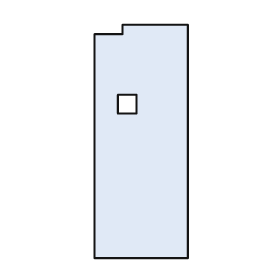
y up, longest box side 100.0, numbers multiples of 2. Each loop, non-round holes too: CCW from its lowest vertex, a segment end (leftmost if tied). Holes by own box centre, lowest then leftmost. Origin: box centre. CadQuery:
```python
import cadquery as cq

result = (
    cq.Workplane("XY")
    .moveTo(-20.0, -50.0)
    .lineTo(20.0, -50.0)
    .lineTo(20.0, 50.0)
    .lineTo(-8.0, 50.0)
    .lineTo(-8.0, 46.0)
    .lineTo(-20.0, 46.0)
    .close()
    .moveTo(-10.0, 12.0)
    .lineTo(-2.0, 12.0)
    .lineTo(-2.0, 20.0)
    .lineTo(-10.0, 20.0)
    .close()
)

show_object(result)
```